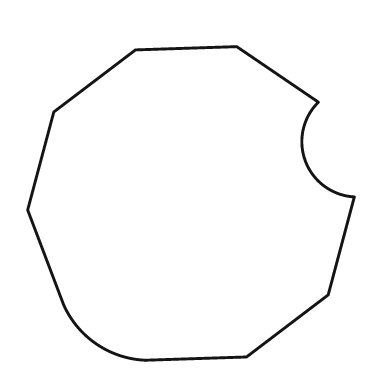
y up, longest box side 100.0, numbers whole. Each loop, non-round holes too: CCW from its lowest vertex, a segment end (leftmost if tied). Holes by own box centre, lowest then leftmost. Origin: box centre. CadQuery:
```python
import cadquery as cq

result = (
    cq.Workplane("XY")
    .moveTo(-14.0, -48.0)
    .lineTo(17.0, -47.0)
    .lineTo(42.0, -28.0)
    .lineTo(50.0, 2.0)
    .threePointArc((35.0, 13.0), (39.0, 31.0))
    .lineTo(14.0, 48.0)
    .lineTo(-17.0, 47.0)
    .lineTo(-42.0, 28.0)
    .lineTo(-50.0, -2.0)
    .lineTo(-39.0, -31.0)
    .threePointArc((-29.0, -43.0), (-14.0, -48.0))
    .close()
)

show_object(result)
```